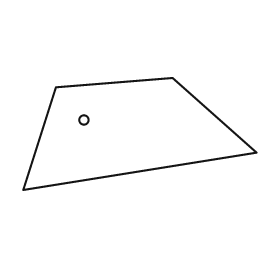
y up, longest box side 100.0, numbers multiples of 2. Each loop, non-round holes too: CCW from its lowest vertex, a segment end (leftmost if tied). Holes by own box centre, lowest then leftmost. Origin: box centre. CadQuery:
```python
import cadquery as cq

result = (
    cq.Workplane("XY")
    .moveTo(-50.0, -24.0)
    .lineTo(50.0, -8.0)
    .lineTo(14.0, 24.0)
    .lineTo(-36.0, 20.0)
    .close()
    .moveTo(-24.0, 6.0)
    .circle(2.0)
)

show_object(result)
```